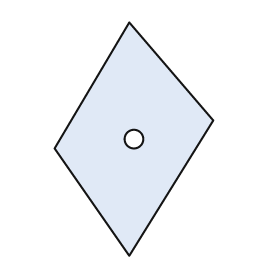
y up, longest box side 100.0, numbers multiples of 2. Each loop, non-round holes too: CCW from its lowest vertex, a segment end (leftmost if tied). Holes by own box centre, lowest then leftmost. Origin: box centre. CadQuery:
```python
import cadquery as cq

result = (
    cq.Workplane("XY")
    .moveTo(-2.0, -50.0)
    .lineTo(34.0, 8.0)
    .lineTo(-2.0, 50.0)
    .lineTo(-34.0, -4.0)
    .close()
    .moveTo(0.0, 0.0)
    .circle(4.0)
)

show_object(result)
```